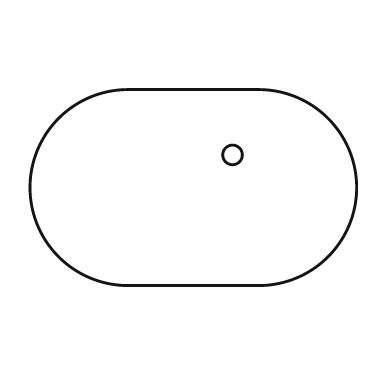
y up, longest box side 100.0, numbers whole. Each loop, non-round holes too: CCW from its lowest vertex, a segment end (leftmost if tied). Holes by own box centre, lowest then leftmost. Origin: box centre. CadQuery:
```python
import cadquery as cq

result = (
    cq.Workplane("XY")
    .moveTo(-20.0, -30.0)
    .lineTo(20.0, -30.0)
    .threePointArc((50.0, 0.0), (20.0, 30.0))
    .lineTo(-20.0, 30.0)
    .threePointArc((-50.0, 0.0), (-20.0, -30.0))
    .close()
    .moveTo(12.0, 10.0)
    .circle(3.0)
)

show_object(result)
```